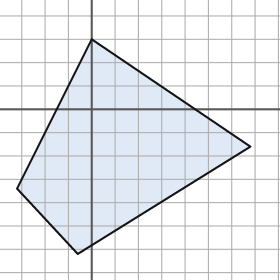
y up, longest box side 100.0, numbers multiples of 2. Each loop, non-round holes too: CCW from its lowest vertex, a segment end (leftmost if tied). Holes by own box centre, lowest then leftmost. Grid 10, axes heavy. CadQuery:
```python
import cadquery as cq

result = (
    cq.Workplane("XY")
    .moveTo(-6.0, -62.0)
    .lineTo(68.0, -16.0)
    .lineTo(0.0, 30.0)
    .lineTo(-32.0, -34.0)
    .close()
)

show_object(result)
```